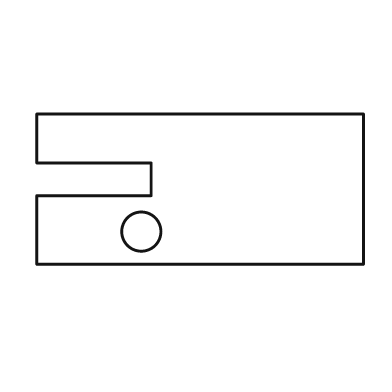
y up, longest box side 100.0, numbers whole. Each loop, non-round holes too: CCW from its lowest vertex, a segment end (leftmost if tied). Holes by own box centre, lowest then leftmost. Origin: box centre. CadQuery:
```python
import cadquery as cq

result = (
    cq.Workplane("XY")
    .moveTo(-50.0, -23.0)
    .lineTo(50.0, -23.0)
    .lineTo(50.0, 23.0)
    .lineTo(-50.0, 23.0)
    .lineTo(-50.0, 8.0)
    .lineTo(-15.0, 8.0)
    .lineTo(-15.0, -2.0)
    .lineTo(-50.0, -2.0)
    .close()
    .moveTo(-18.0, -13.0)
    .circle(6.0)
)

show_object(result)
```